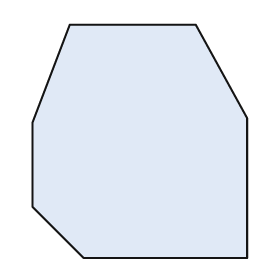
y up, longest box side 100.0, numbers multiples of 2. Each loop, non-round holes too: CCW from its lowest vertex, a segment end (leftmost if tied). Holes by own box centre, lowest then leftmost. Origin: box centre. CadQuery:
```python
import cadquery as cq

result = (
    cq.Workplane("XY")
    .moveTo(-24.0, -50.0)
    .lineTo(46.0, -50.0)
    .lineTo(46.0, 10.0)
    .lineTo(24.0, 50.0)
    .lineTo(-30.0, 50.0)
    .lineTo(-46.0, 8.0)
    .lineTo(-46.0, -28.0)
    .close()
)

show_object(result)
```